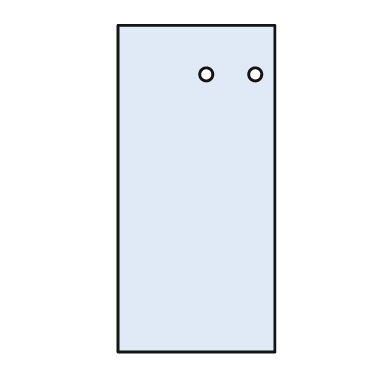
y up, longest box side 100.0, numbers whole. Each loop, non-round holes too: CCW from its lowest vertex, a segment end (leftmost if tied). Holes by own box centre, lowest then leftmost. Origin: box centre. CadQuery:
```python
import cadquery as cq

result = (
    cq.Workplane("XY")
    .moveTo(-24.0, -50.0)
    .lineTo(24.0, -50.0)
    .lineTo(24.0, 50.0)
    .lineTo(-24.0, 50.0)
    .close()
    .moveTo(3.0, 35.0)
    .circle(2.0)
    .moveTo(18.0, 35.0)
    .circle(2.0)
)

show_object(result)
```